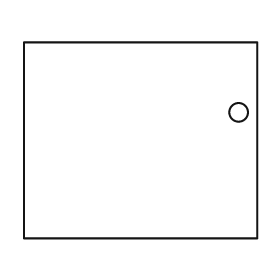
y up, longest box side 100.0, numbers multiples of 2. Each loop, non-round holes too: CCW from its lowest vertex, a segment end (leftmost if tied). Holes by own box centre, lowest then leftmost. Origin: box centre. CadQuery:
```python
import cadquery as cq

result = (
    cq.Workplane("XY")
    .moveTo(-50.0, -42.0)
    .lineTo(50.0, -42.0)
    .lineTo(50.0, 42.0)
    .lineTo(-50.0, 42.0)
    .close()
    .moveTo(42.0, 12.0)
    .circle(4.0)
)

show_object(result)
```